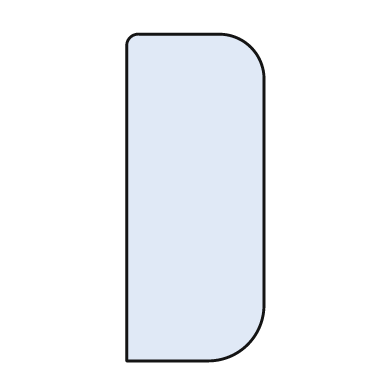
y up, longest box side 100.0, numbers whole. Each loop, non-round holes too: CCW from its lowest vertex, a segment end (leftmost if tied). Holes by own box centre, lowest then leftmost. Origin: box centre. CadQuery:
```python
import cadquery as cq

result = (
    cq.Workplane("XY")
    .moveTo(-21.0, -50.0)
    .lineTo(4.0, -50.0)
    .threePointArc((16.0, -45.0), (21.0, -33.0))
    .lineTo(21.0, 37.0)
    .threePointArc((17.0, 46.0), (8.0, 50.0))
    .lineTo(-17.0, 50.0)
    .threePointArc((-20.0, 49.0), (-21.0, 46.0))
    .close()
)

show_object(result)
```